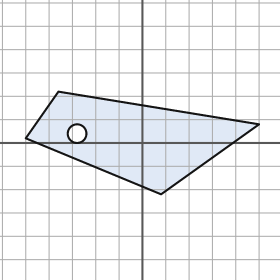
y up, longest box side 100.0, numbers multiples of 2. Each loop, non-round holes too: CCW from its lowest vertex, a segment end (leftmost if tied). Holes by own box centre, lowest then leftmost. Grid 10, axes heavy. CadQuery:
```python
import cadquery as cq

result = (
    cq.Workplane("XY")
    .moveTo(8.0, -22.0)
    .lineTo(50.0, 8.0)
    .lineTo(-36.0, 22.0)
    .lineTo(-50.0, 2.0)
    .close()
    .moveTo(-28.0, 4.0)
    .circle(4.0)
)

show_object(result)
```